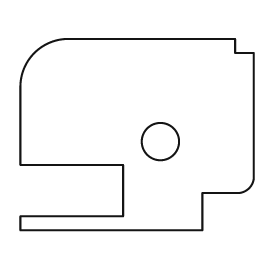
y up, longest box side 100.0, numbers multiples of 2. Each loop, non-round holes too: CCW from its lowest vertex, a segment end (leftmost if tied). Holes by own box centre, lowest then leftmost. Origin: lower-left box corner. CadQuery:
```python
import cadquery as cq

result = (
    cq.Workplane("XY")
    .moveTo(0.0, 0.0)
    .lineTo(78.0, 0.0)
    .lineTo(78.0, 16.0)
    .lineTo(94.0, 16.0)
    .threePointArc((98.0, 18.0), (100.0, 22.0))
    .lineTo(100.0, 76.0)
    .lineTo(92.0, 76.0)
    .lineTo(92.0, 82.0)
    .lineTo(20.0, 82.0)
    .threePointArc((6.0, 76.0), (0.0, 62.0))
    .lineTo(0.0, 28.0)
    .lineTo(44.0, 28.0)
    .lineTo(44.0, 6.0)
    .lineTo(0.0, 6.0)
    .close()
    .moveTo(60.0, 38.0)
    .circle(8.0)
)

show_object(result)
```